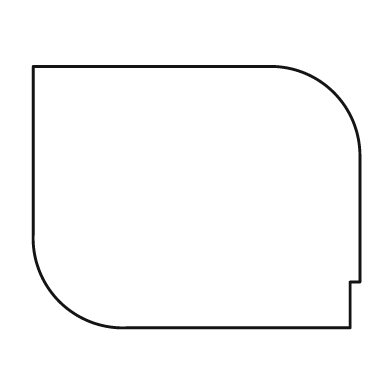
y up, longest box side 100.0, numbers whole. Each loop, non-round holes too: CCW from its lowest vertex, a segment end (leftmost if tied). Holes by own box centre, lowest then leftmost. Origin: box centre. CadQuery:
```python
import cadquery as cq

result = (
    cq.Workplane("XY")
    .moveTo(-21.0, -40.0)
    .lineTo(47.0, -40.0)
    .lineTo(47.0, -26.0)
    .lineTo(50.0, -26.0)
    .lineTo(50.0, 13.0)
    .threePointArc((42.0, 32.0), (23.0, 40.0))
    .lineTo(-50.0, 40.0)
    .lineTo(-50.0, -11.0)
    .threePointArc((-42.0, -32.0), (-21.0, -40.0))
    .close()
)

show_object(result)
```